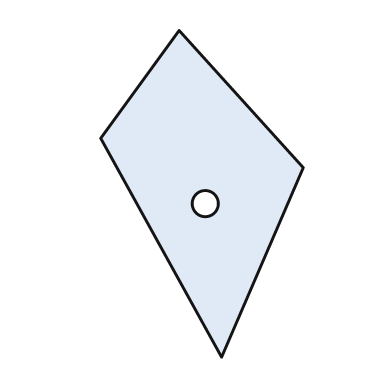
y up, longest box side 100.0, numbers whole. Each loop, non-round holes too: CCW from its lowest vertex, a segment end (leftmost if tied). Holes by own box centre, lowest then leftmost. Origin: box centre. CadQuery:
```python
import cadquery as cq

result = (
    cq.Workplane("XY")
    .moveTo(6.0, -50.0)
    .lineTo(31.0, 8.0)
    .lineTo(-7.0, 50.0)
    .lineTo(-31.0, 17.0)
    .close()
    .moveTo(1.0, -3.0)
    .circle(4.0)
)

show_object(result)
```